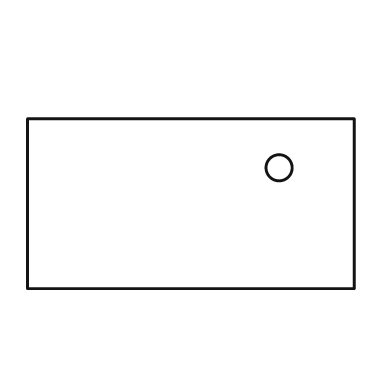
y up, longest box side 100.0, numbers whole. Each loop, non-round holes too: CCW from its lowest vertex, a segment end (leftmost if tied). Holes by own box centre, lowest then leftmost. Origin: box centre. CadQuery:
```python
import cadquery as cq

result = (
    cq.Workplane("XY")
    .moveTo(-50.0, -26.0)
    .lineTo(50.0, -26.0)
    .lineTo(50.0, 26.0)
    .lineTo(-50.0, 26.0)
    .close()
    .moveTo(27.0, 11.0)
    .circle(4.0)
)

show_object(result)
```